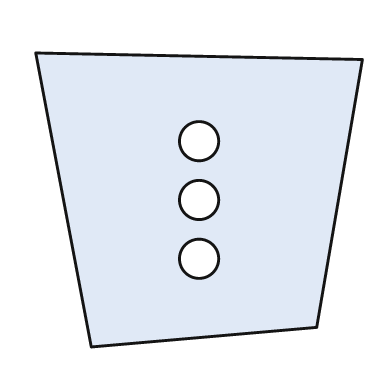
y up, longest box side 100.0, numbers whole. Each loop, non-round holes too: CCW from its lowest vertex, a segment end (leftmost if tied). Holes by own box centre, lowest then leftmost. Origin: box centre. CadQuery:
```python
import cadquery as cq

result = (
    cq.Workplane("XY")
    .moveTo(-33.0, -45.0)
    .lineTo(36.0, -39.0)
    .lineTo(50.0, 43.0)
    .lineTo(-50.0, 45.0)
    .close()
    .moveTo(0.0, -18.0)
    .circle(6.0)
    .moveTo(0.0, 0.0)
    .circle(6.0)
    .moveTo(0.0, 18.0)
    .circle(6.0)
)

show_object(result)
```